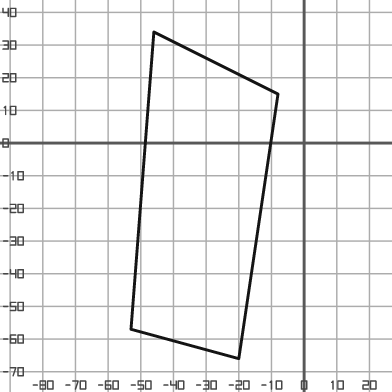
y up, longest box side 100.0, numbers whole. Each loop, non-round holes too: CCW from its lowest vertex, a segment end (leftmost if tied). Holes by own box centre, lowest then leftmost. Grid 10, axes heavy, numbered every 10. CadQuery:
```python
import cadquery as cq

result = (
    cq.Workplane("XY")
    .moveTo(-20.0, -66.0)
    .lineTo(-8.0, 15.0)
    .lineTo(-46.0, 34.0)
    .lineTo(-53.0, -57.0)
    .close()
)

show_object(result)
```